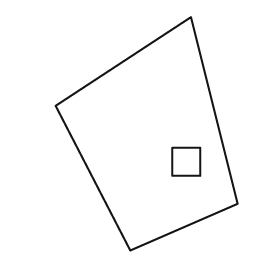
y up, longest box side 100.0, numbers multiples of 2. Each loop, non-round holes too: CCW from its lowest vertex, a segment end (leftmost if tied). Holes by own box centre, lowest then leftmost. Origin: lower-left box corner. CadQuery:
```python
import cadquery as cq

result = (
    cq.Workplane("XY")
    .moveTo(32.0, 0.0)
    .lineTo(78.0, 20.0)
    .lineTo(58.0, 100.0)
    .lineTo(0.0, 62.0)
    .close()
    .moveTo(50.0, 32.0)
    .lineTo(62.0, 32.0)
    .lineTo(62.0, 44.0)
    .lineTo(50.0, 44.0)
    .close()
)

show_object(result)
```